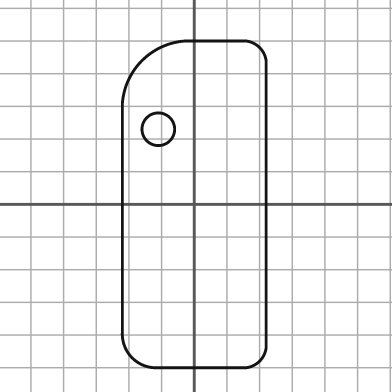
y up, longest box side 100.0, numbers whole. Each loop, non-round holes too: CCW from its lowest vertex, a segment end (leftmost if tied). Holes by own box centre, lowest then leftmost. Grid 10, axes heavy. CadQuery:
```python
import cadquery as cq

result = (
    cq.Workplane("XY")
    .moveTo(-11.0, -50.0)
    .lineTo(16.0, -50.0)
    .threePointArc((20.0, -48.0), (22.0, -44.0))
    .lineTo(22.0, 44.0)
    .threePointArc((20.0, 48.0), (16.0, 50.0))
    .lineTo(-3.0, 50.0)
    .threePointArc((-16.0, 44.0), (-22.0, 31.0))
    .lineTo(-22.0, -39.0)
    .threePointArc((-19.0, -47.0), (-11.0, -50.0))
    .close()
    .moveTo(-11.0, 23.0)
    .circle(5.0)
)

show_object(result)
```